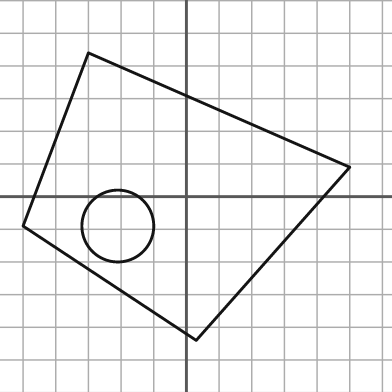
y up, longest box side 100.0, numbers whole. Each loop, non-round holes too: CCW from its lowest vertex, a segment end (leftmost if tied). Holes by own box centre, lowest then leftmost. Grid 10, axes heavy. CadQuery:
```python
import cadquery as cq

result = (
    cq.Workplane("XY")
    .moveTo(3.0, -44.0)
    .lineTo(50.0, 9.0)
    .lineTo(-30.0, 44.0)
    .lineTo(-50.0, -9.0)
    .close()
    .moveTo(-21.0, -9.0)
    .circle(11.0)
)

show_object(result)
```